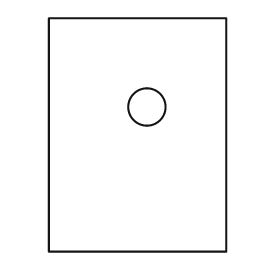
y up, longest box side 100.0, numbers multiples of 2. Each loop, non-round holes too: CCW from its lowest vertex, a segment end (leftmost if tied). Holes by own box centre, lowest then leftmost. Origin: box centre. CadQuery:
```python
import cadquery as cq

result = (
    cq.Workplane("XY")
    .moveTo(-38.0, -50.0)
    .lineTo(38.0, -50.0)
    .lineTo(38.0, 50.0)
    .lineTo(-38.0, 50.0)
    .close()
    .moveTo(4.0, 12.0)
    .circle(8.0)
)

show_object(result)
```